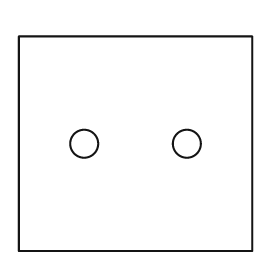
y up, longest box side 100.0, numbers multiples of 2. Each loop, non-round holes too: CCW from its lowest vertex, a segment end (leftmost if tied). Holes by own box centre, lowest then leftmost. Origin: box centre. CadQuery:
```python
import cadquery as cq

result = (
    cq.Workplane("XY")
    .moveTo(-50.0, -46.0)
    .lineTo(50.0, -46.0)
    .lineTo(50.0, 46.0)
    .lineTo(-50.0, 46.0)
    .close()
    .moveTo(-22.0, 0.0)
    .circle(6.0)
    .moveTo(22.0, 0.0)
    .circle(6.0)
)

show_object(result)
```